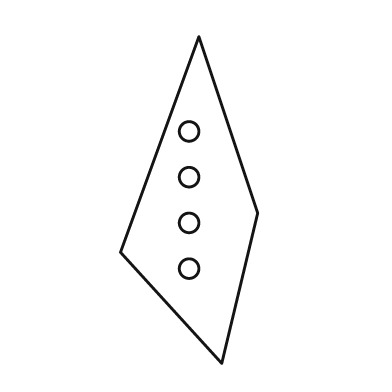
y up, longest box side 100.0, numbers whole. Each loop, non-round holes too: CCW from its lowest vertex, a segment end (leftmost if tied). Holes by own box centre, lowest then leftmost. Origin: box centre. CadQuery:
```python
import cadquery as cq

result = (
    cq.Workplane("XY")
    .moveTo(10.0, -50.0)
    .lineTo(21.0, -4.0)
    .lineTo(3.0, 50.0)
    .lineTo(-21.0, -16.0)
    .close()
    .moveTo(0.0, -21.0)
    .circle(3.0)
    .moveTo(0.0, -7.0)
    .circle(3.0)
    .moveTo(0.0, 7.0)
    .circle(3.0)
    .moveTo(0.0, 21.0)
    .circle(3.0)
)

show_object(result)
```